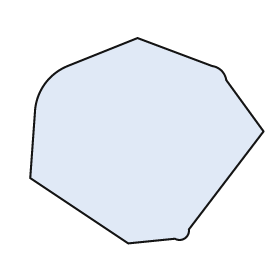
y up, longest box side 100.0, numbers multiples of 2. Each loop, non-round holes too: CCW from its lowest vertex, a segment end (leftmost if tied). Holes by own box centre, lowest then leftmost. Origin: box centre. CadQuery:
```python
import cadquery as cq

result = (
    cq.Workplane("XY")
    .moveTo(-8.0, -44.0)
    .lineTo(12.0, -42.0)
    .threePointArc((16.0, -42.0), (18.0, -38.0))
    .lineTo(50.0, 4.0)
    .lineTo(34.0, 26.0)
    .threePointArc((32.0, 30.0), (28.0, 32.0))
    .lineTo(-4.0, 44.0)
    .lineTo(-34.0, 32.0)
    .threePointArc((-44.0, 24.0), (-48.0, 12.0))
    .lineTo(-50.0, -16.0)
    .close()
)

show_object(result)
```